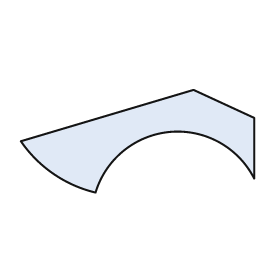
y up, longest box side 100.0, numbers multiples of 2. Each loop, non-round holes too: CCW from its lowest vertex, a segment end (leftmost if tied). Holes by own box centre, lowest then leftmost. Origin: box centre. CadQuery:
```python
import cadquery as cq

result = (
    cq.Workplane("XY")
    .moveTo(-18.0, -22.0)
    .threePointArc((14.0, 4.0), (50.0, -16.0))
    .lineTo(50.0, 10.0)
    .lineTo(24.0, 22.0)
    .lineTo(-50.0, 0.0)
    .threePointArc((-36.0, -14.0), (-18.0, -22.0))
    .close()
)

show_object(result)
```